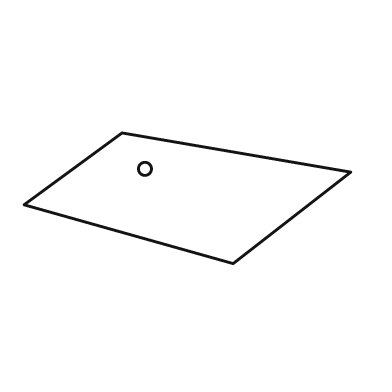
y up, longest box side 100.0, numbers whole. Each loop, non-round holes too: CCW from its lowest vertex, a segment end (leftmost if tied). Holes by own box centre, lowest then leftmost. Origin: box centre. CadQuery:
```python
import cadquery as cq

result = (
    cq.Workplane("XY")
    .moveTo(14.0, -20.0)
    .lineTo(50.0, 8.0)
    .lineTo(-20.0, 20.0)
    .lineTo(-50.0, -2.0)
    .close()
    .moveTo(-13.0, 9.0)
    .circle(2.0)
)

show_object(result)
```